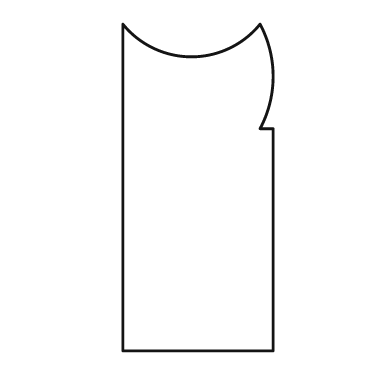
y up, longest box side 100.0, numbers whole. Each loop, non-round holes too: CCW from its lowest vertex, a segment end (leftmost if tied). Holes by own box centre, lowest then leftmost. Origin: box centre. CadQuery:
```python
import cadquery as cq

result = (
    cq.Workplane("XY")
    .moveTo(-23.0, -50.0)
    .lineTo(23.0, -50.0)
    .lineTo(23.0, 18.0)
    .lineTo(19.0, 18.0)
    .threePointArc((23.0, 34.0), (19.0, 50.0))
    .threePointArc((-2.0, 40.0), (-23.0, 50.0))
    .close()
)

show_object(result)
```